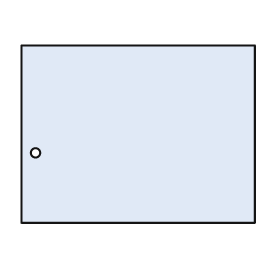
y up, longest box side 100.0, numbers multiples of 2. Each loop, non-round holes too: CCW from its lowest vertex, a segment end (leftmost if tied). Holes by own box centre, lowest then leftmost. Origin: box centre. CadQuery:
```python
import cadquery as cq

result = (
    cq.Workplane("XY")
    .moveTo(-50.0, -38.0)
    .lineTo(50.0, -38.0)
    .lineTo(50.0, 38.0)
    .lineTo(-50.0, 38.0)
    .close()
    .moveTo(-44.0, -8.0)
    .circle(2.0)
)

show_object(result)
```